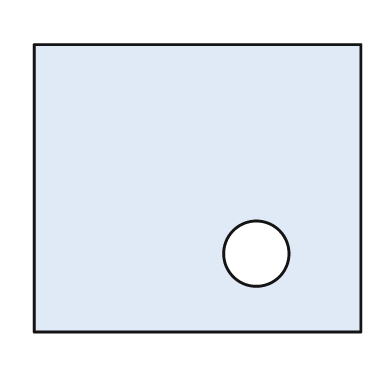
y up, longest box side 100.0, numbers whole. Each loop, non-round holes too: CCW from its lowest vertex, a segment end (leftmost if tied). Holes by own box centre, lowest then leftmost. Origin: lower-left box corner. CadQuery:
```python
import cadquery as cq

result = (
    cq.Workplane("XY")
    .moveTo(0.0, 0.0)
    .lineTo(100.0, 0.0)
    .lineTo(100.0, 88.0)
    .lineTo(0.0, 88.0)
    .close()
    .moveTo(68.0, 24.0)
    .circle(10.0)
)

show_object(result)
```